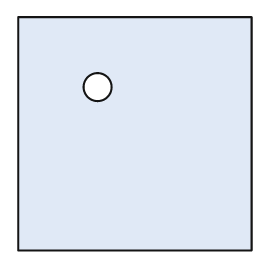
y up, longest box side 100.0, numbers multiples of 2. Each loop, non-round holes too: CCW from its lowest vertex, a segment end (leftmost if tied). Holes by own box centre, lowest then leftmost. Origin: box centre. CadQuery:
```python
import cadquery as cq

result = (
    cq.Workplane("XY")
    .moveTo(-50.0, -50.0)
    .lineTo(50.0, -50.0)
    .lineTo(50.0, 50.0)
    .lineTo(-50.0, 50.0)
    .close()
    .moveTo(-16.0, 20.0)
    .circle(6.0)
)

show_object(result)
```